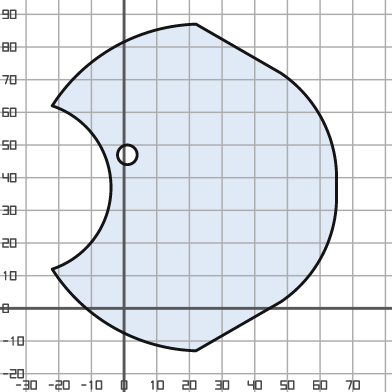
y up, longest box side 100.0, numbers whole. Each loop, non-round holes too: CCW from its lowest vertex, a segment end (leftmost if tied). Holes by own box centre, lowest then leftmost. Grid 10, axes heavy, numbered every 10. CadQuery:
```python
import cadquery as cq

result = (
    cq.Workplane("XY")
    .moveTo(22.0, -13.0)
    .lineTo(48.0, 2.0)
    .threePointArc((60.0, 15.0), (65.0, 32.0))
    .lineTo(65.0, 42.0)
    .threePointArc((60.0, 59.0), (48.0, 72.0))
    .lineTo(22.0, 87.0)
    .threePointArc((-3.0, 80.0), (-22.0, 62.0))
    .threePointArc((-4.0, 37.0), (-22.0, 12.0))
    .threePointArc((-3.0, -6.0), (22.0, -13.0))
    .close()
    .moveTo(1.0, 47.0)
    .circle(3.0)
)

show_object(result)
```